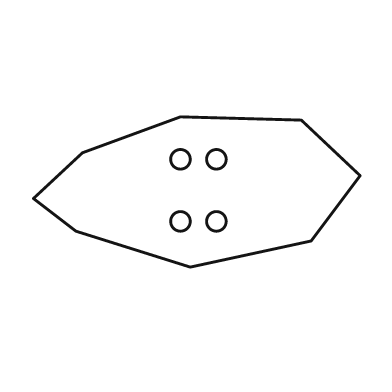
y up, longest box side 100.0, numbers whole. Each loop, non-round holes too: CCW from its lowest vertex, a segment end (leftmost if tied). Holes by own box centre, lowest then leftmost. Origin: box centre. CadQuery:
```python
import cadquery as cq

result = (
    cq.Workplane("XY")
    .moveTo(-2.0, -23.0)
    .lineTo(35.0, -15.0)
    .lineTo(50.0, 5.0)
    .lineTo(32.0, 22.0)
    .lineTo(-5.0, 23.0)
    .lineTo(-35.0, 12.0)
    .lineTo(-50.0, -2.0)
    .lineTo(-37.0, -12.0)
    .close()
    .moveTo(-5.0, -9.0)
    .circle(3.0)
    .moveTo(6.0, -9.0)
    .circle(3.0)
    .moveTo(-5.0, 10.0)
    .circle(3.0)
    .moveTo(6.0, 10.0)
    .circle(3.0)
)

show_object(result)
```